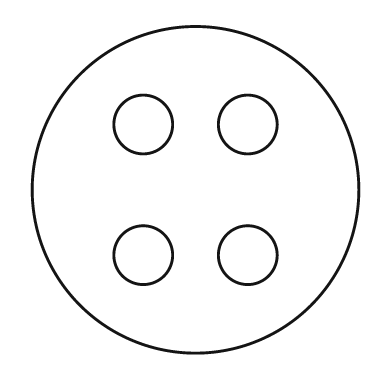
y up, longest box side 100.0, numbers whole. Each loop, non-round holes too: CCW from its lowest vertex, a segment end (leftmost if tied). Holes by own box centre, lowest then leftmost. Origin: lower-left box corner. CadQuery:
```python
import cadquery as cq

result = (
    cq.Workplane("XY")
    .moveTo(50.0, 50.0)
    .circle(50.0)
    .moveTo(34.0, 30.0)
    .circle(9.0)
    .moveTo(66.0, 30.0)
    .circle(9.0)
    .moveTo(34.0, 70.0)
    .circle(9.0)
    .moveTo(66.0, 70.0)
    .circle(9.0)
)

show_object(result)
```